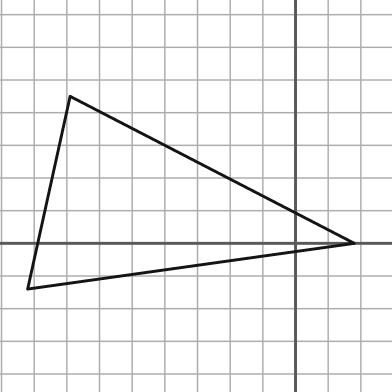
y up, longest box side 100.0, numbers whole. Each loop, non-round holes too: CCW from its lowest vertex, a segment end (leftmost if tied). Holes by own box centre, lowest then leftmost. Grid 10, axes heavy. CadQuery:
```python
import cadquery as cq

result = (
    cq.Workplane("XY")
    .moveTo(-82.0, -14.0)
    .lineTo(18.0, 0.0)
    .lineTo(-69.0, 45.0)
    .close()
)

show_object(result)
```